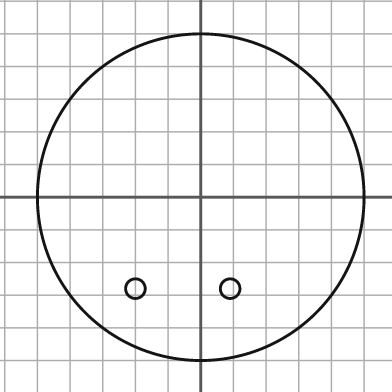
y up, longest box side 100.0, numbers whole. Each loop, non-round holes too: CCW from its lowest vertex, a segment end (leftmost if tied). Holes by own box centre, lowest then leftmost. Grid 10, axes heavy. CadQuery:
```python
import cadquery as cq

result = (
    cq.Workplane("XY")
    .moveTo(0.0, 0.0)
    .circle(50.0)
    .moveTo(-20.0, -28.0)
    .circle(3.0)
    .moveTo(9.0, -28.0)
    .circle(3.0)
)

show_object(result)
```